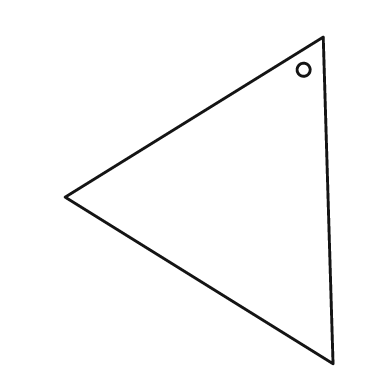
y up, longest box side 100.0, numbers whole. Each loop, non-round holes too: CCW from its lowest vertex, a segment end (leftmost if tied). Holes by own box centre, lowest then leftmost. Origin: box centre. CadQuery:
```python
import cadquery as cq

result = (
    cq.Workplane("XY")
    .moveTo(41.0, -50.0)
    .lineTo(38.0, 50.0)
    .lineTo(-41.0, 1.0)
    .close()
    .moveTo(32.0, 40.0)
    .circle(2.0)
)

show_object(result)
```